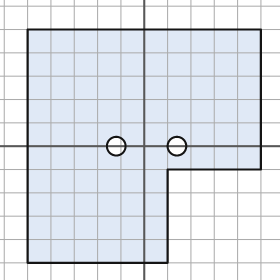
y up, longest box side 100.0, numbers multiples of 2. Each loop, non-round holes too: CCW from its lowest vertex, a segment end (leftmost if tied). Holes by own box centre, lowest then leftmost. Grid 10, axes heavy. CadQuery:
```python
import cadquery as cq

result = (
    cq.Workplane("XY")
    .moveTo(-50.0, -50.0)
    .lineTo(10.0, -50.0)
    .lineTo(10.0, -10.0)
    .lineTo(50.0, -10.0)
    .lineTo(50.0, 50.0)
    .lineTo(-50.0, 50.0)
    .close()
    .moveTo(-12.0, 0.0)
    .circle(4.0)
    .moveTo(14.0, 0.0)
    .circle(4.0)
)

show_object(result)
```